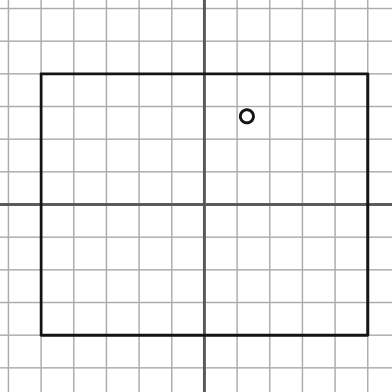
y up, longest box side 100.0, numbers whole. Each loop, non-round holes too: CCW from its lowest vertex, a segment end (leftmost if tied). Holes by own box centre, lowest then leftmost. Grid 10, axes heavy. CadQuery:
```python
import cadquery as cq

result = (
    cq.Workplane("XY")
    .moveTo(-50.0, -40.0)
    .lineTo(50.0, -40.0)
    .lineTo(50.0, 40.0)
    .lineTo(-50.0, 40.0)
    .close()
    .moveTo(13.0, 27.0)
    .circle(2.0)
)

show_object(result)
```